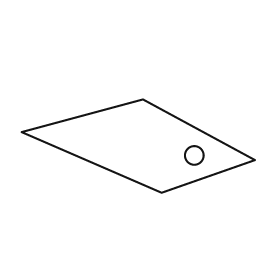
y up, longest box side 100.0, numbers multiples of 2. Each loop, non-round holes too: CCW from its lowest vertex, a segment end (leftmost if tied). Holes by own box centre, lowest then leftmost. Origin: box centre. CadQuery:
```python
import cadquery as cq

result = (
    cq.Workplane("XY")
    .moveTo(10.0, -20.0)
    .lineTo(50.0, -6.0)
    .lineTo(2.0, 20.0)
    .lineTo(-50.0, 6.0)
    .close()
    .moveTo(24.0, -4.0)
    .circle(4.0)
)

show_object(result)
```